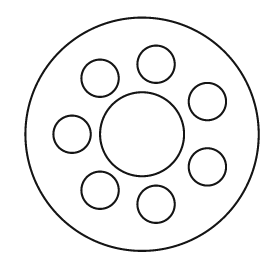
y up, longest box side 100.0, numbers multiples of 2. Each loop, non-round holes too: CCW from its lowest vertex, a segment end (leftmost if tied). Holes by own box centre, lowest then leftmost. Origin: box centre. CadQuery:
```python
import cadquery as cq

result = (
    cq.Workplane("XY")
    .moveTo(0.0, 0.0)
    .circle(50.0)
    .moveTo(6.0, -30.0)
    .circle(8.0)
    .moveTo(-18.0, -24.0)
    .circle(8.0)
    .moveTo(28.0, -14.0)
    .circle(8.0)
    .moveTo(-30.0, 0.0)
    .circle(8.0)
    .moveTo(0.0, 0.0)
    .circle(18.0)
    .moveTo(28.0, 14.0)
    .circle(8.0)
    .moveTo(-18.0, 24.0)
    .circle(8.0)
    .moveTo(6.0, 30.0)
    .circle(8.0)
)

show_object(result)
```